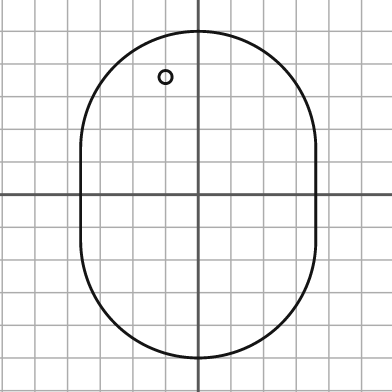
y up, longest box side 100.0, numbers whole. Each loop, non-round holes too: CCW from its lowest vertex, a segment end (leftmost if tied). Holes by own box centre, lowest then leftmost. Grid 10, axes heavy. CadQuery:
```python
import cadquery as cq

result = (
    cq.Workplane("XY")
    .moveTo(-36.0, -14.0)
    .threePointArc((0.0, -50.0), (36.0, -14.0))
    .lineTo(36.0, 14.0)
    .threePointArc((0.0, 50.0), (-36.0, 14.0))
    .close()
    .moveTo(-10.0, 36.0)
    .circle(2.0)
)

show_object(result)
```